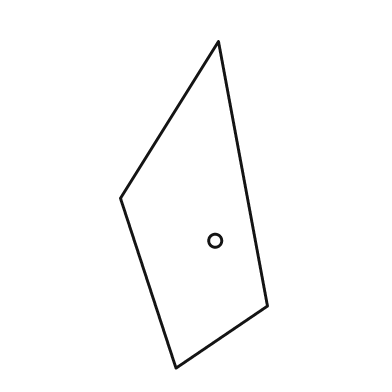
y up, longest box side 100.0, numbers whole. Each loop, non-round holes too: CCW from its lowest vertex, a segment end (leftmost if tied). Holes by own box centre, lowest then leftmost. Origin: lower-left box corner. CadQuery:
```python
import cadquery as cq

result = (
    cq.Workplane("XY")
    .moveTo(17.0, 0.0)
    .lineTo(45.0, 19.0)
    .lineTo(30.0, 100.0)
    .lineTo(0.0, 52.0)
    .close()
    .moveTo(29.0, 39.0)
    .circle(2.0)
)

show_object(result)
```